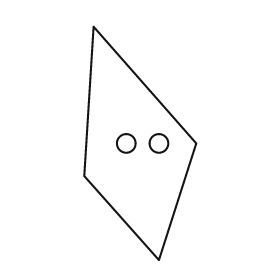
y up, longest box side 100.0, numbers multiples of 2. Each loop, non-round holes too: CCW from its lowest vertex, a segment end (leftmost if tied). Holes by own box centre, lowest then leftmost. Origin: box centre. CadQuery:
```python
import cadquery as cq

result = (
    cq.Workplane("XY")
    .moveTo(8.0, -50.0)
    .lineTo(24.0, 0.0)
    .lineTo(-20.0, 50.0)
    .lineTo(-24.0, -14.0)
    .close()
    .moveTo(-6.0, 0.0)
    .circle(4.0)
    .moveTo(8.0, 0.0)
    .circle(4.0)
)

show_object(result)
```